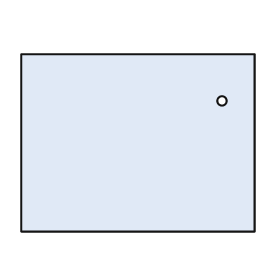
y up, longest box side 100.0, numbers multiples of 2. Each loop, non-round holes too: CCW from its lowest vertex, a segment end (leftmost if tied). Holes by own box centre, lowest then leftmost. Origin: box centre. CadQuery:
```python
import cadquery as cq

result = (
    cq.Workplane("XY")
    .moveTo(-50.0, -38.0)
    .lineTo(50.0, -38.0)
    .lineTo(50.0, 38.0)
    .lineTo(-50.0, 38.0)
    .close()
    .moveTo(36.0, 18.0)
    .circle(2.0)
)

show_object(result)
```